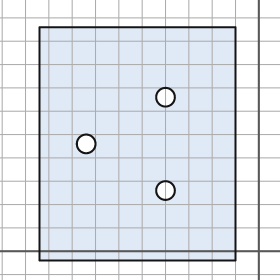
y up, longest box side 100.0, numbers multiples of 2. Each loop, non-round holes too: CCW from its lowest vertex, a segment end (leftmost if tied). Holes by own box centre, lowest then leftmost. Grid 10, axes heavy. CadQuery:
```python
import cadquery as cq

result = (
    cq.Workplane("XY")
    .moveTo(-94.0, -4.0)
    .lineTo(-10.0, -4.0)
    .lineTo(-10.0, 96.0)
    .lineTo(-94.0, 96.0)
    .close()
    .moveTo(-40.0, 26.0)
    .circle(4.0)
    .moveTo(-74.0, 46.0)
    .circle(4.0)
    .moveTo(-40.0, 66.0)
    .circle(4.0)
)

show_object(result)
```